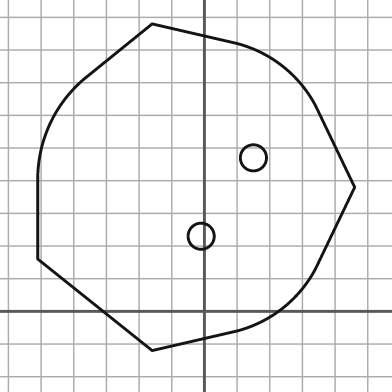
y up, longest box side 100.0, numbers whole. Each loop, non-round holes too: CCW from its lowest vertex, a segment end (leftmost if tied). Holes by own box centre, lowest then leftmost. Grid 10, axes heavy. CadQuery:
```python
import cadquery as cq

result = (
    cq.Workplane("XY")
    .moveTo(-16.0, -12.0)
    .lineTo(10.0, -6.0)
    .threePointArc((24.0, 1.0), (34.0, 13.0))
    .lineTo(46.0, 38.0)
    .lineTo(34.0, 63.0)
    .threePointArc((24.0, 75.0), (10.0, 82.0))
    .lineTo(-16.0, 88.0)
    .lineTo(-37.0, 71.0)
    .threePointArc((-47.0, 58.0), (-51.0, 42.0))
    .lineTo(-51.0, 16.0)
    .close()
    .moveTo(-1.0, 23.0)
    .circle(4.0)
    .moveTo(15.0, 47.0)
    .circle(4.0)
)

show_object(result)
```